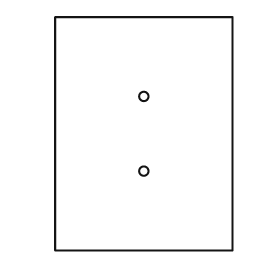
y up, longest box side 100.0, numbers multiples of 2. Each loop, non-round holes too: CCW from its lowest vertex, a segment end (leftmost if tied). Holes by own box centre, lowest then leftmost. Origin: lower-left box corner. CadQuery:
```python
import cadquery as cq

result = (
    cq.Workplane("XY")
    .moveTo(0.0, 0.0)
    .lineTo(76.0, 0.0)
    .lineTo(76.0, 100.0)
    .lineTo(0.0, 100.0)
    .close()
    .moveTo(38.0, 34.0)
    .circle(2.0)
    .moveTo(38.0, 66.0)
    .circle(2.0)
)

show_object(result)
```